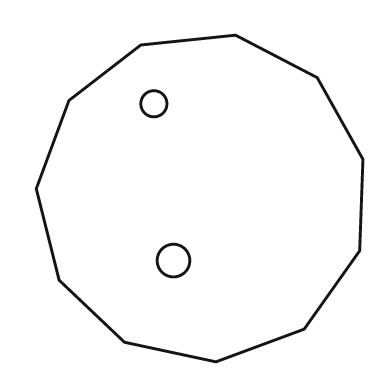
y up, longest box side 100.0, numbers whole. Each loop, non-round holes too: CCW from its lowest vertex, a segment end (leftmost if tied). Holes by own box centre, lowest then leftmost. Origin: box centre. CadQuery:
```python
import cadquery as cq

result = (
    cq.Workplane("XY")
    .moveTo(5.0, -50.0)
    .lineTo(32.0, -40.0)
    .lineTo(49.0, -16.0)
    .lineTo(50.0, 12.0)
    .lineTo(36.0, 37.0)
    .lineTo(11.0, 50.0)
    .lineTo(-18.0, 47.0)
    .lineTo(-40.0, 30.0)
    .lineTo(-50.0, 3.0)
    .lineTo(-43.0, -25.0)
    .lineTo(-23.0, -44.0)
    .close()
    .moveTo(-8.0, -19.0)
    .circle(5.0)
    .moveTo(-14.0, 29.0)
    .circle(4.0)
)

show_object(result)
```